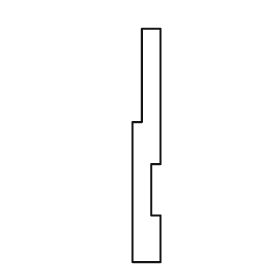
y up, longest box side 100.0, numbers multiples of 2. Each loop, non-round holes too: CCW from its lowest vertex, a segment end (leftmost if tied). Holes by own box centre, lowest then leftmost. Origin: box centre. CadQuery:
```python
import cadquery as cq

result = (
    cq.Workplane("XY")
    .moveTo(-6.0, -50.0)
    .lineTo(6.0, -50.0)
    .lineTo(6.0, -30.0)
    .lineTo(2.0, -30.0)
    .lineTo(2.0, -8.0)
    .lineTo(6.0, -8.0)
    .lineTo(6.0, 50.0)
    .lineTo(-2.0, 50.0)
    .lineTo(-2.0, 10.0)
    .lineTo(-6.0, 10.0)
    .close()
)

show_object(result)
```